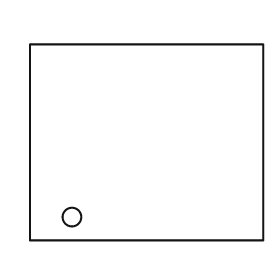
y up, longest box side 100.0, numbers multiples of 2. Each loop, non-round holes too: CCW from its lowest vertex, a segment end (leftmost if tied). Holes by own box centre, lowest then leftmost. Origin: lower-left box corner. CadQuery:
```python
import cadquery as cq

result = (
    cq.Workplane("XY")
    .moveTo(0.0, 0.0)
    .lineTo(100.0, 0.0)
    .lineTo(100.0, 84.0)
    .lineTo(0.0, 84.0)
    .close()
    .moveTo(18.0, 10.0)
    .circle(4.0)
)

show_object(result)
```